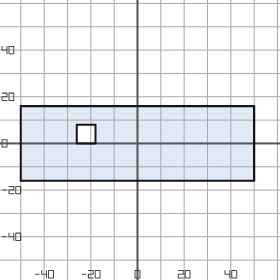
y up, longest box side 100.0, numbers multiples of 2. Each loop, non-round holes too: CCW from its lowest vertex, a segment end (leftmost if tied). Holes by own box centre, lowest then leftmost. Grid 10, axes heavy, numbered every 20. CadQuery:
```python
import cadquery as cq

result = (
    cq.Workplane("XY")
    .moveTo(-50.0, -16.0)
    .lineTo(50.0, -16.0)
    .lineTo(50.0, 16.0)
    .lineTo(-50.0, 16.0)
    .close()
    .moveTo(-26.0, 0.0)
    .lineTo(-18.0, 0.0)
    .lineTo(-18.0, 8.0)
    .lineTo(-26.0, 8.0)
    .close()
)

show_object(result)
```